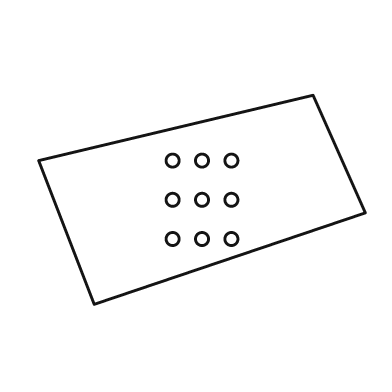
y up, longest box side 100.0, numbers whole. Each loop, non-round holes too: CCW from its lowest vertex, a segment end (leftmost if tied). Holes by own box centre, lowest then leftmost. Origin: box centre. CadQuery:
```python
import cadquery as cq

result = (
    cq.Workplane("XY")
    .moveTo(-33.0, -32.0)
    .lineTo(50.0, -4.0)
    .lineTo(34.0, 32.0)
    .lineTo(-50.0, 12.0)
    .close()
    .moveTo(-9.0, -12.0)
    .circle(2.0)
    .moveTo(0.0, -12.0)
    .circle(2.0)
    .moveTo(9.0, -12.0)
    .circle(2.0)
    .moveTo(-9.0, 0.0)
    .circle(2.0)
    .moveTo(0.0, 0.0)
    .circle(2.0)
    .moveTo(9.0, 0.0)
    .circle(2.0)
    .moveTo(-9.0, 12.0)
    .circle(2.0)
    .moveTo(0.0, 12.0)
    .circle(2.0)
    .moveTo(9.0, 12.0)
    .circle(2.0)
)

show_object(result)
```